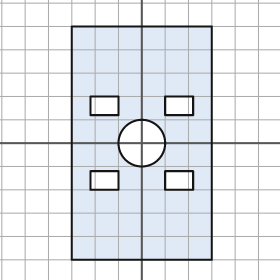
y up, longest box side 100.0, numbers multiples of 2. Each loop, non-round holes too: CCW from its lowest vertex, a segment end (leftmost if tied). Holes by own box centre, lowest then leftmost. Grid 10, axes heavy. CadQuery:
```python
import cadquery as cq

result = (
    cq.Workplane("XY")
    .moveTo(-30.0, -50.0)
    .lineTo(30.0, -50.0)
    .lineTo(30.0, 50.0)
    .lineTo(-30.0, 50.0)
    .close()
    .moveTo(-22.0, -20.0)
    .lineTo(-10.0, -20.0)
    .lineTo(-10.0, -12.0)
    .lineTo(-22.0, -12.0)
    .close()
    .moveTo(10.0, -20.0)
    .lineTo(22.0, -20.0)
    .lineTo(22.0, -12.0)
    .lineTo(10.0, -12.0)
    .close()
    .moveTo(0.0, 0.0)
    .circle(10.0)
    .moveTo(-22.0, 12.0)
    .lineTo(-10.0, 12.0)
    .lineTo(-10.0, 20.0)
    .lineTo(-22.0, 20.0)
    .close()
    .moveTo(10.0, 12.0)
    .lineTo(22.0, 12.0)
    .lineTo(22.0, 20.0)
    .lineTo(10.0, 20.0)
    .close()
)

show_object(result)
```